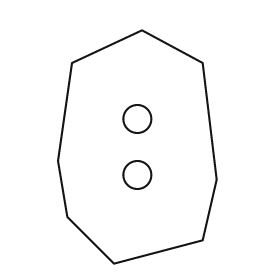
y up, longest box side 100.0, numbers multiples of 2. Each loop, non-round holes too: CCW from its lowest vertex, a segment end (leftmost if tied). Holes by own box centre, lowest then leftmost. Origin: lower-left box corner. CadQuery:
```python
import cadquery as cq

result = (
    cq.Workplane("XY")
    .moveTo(24.0, 0.0)
    .lineTo(62.0, 10.0)
    .lineTo(68.0, 36.0)
    .lineTo(62.0, 86.0)
    .lineTo(36.0, 100.0)
    .lineTo(6.0, 86.0)
    .lineTo(0.0, 44.0)
    .lineTo(4.0, 20.0)
    .close()
    .moveTo(34.0, 38.0)
    .circle(6.0)
    .moveTo(34.0, 62.0)
    .circle(6.0)
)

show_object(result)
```